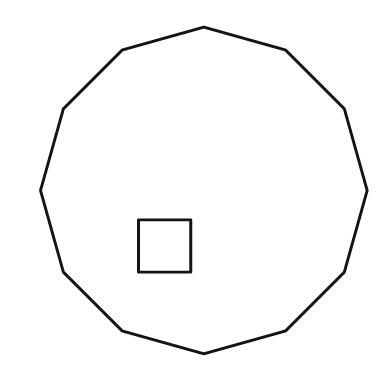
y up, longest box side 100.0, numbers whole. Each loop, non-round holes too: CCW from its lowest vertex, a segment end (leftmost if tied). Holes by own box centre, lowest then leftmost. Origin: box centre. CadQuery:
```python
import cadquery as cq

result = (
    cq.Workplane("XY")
    .moveTo(0.0, -50.0)
    .lineTo(25.0, -43.0)
    .lineTo(43.0, -25.0)
    .lineTo(50.0, 0.0)
    .lineTo(43.0, 25.0)
    .lineTo(25.0, 43.0)
    .lineTo(0.0, 50.0)
    .lineTo(-25.0, 43.0)
    .lineTo(-43.0, 25.0)
    .lineTo(-50.0, 0.0)
    .lineTo(-43.0, -25.0)
    .lineTo(-25.0, -43.0)
    .close()
    .moveTo(-20.0, -25.0)
    .lineTo(-4.0, -25.0)
    .lineTo(-4.0, -9.0)
    .lineTo(-20.0, -9.0)
    .close()
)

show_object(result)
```